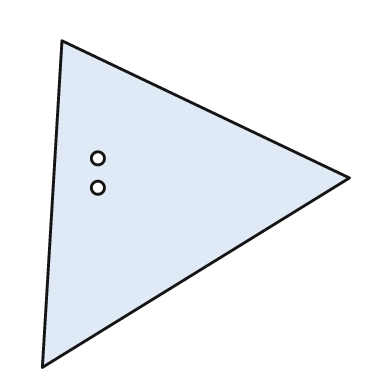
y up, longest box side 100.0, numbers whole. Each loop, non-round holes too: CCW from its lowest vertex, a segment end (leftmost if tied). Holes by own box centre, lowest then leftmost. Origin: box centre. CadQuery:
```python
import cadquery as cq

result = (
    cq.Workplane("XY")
    .moveTo(-47.0, -50.0)
    .lineTo(47.0, 8.0)
    .lineTo(-41.0, 50.0)
    .close()
    .moveTo(-30.0, 5.0)
    .circle(2.0)
    .moveTo(-30.0, 14.0)
    .circle(2.0)
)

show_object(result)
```